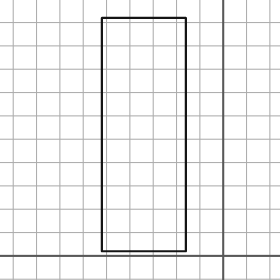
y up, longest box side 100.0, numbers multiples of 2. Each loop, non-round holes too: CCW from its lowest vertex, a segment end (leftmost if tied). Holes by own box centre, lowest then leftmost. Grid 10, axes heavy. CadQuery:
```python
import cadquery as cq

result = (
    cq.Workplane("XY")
    .moveTo(-52.0, 2.0)
    .lineTo(-16.0, 2.0)
    .lineTo(-16.0, 102.0)
    .lineTo(-52.0, 102.0)
    .close()
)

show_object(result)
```